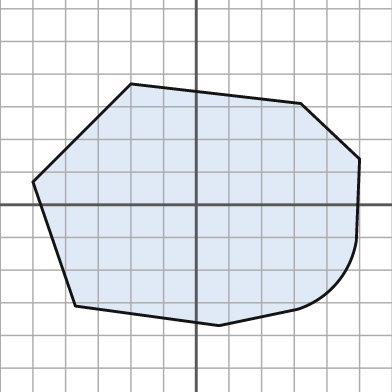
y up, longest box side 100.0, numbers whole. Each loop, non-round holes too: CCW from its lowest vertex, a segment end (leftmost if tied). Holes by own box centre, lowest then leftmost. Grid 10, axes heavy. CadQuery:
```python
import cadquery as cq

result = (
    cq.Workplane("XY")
    .moveTo(7.0, -37.0)
    .lineTo(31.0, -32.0)
    .threePointArc((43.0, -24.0), (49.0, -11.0))
    .lineTo(50.0, 14.0)
    .lineTo(32.0, 31.0)
    .lineTo(-20.0, 37.0)
    .lineTo(-50.0, 7.0)
    .lineTo(-37.0, -31.0)
    .close()
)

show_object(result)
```